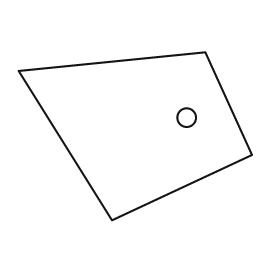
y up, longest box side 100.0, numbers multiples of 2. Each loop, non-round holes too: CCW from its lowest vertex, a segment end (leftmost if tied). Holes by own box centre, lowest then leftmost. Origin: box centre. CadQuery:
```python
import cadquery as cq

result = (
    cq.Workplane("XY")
    .moveTo(-10.0, -36.0)
    .lineTo(50.0, -8.0)
    .lineTo(30.0, 36.0)
    .lineTo(-50.0, 28.0)
    .close()
    .moveTo(22.0, 8.0)
    .circle(4.0)
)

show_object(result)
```